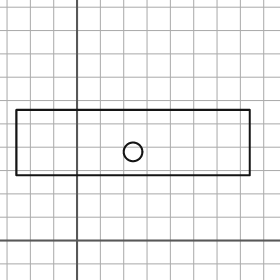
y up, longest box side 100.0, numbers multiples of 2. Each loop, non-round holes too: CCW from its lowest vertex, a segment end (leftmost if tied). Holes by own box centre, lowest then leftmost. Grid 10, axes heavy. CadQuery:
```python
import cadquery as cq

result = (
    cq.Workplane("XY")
    .moveTo(-26.0, 28.0)
    .lineTo(74.0, 28.0)
    .lineTo(74.0, 56.0)
    .lineTo(-26.0, 56.0)
    .close()
    .moveTo(24.0, 38.0)
    .circle(4.0)
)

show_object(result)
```